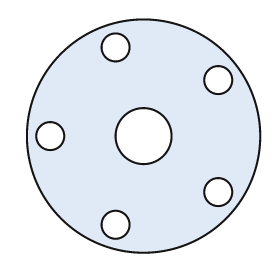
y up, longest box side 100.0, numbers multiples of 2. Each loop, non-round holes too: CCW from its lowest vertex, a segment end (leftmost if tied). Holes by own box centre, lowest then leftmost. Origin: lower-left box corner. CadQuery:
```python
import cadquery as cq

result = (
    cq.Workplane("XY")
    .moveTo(50.0, 50.0)
    .circle(50.0)
    .moveTo(38.0, 12.0)
    .circle(6.0)
    .moveTo(82.0, 26.0)
    .circle(6.0)
    .moveTo(10.0, 50.0)
    .circle(6.0)
    .moveTo(50.0, 50.0)
    .circle(12.0)
    .moveTo(82.0, 74.0)
    .circle(6.0)
    .moveTo(38.0, 88.0)
    .circle(6.0)
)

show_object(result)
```